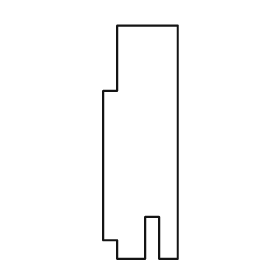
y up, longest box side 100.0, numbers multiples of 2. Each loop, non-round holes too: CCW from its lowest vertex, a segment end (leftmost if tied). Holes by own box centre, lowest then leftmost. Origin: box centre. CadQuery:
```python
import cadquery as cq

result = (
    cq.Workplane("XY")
    .moveTo(-10.0, -50.0)
    .lineTo(2.0, -50.0)
    .lineTo(2.0, -32.0)
    .lineTo(8.0, -32.0)
    .lineTo(8.0, -50.0)
    .lineTo(16.0, -50.0)
    .lineTo(16.0, 50.0)
    .lineTo(-10.0, 50.0)
    .lineTo(-10.0, 22.0)
    .lineTo(-16.0, 22.0)
    .lineTo(-16.0, -42.0)
    .lineTo(-10.0, -42.0)
    .close()
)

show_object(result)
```